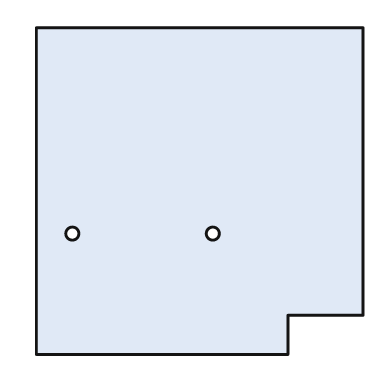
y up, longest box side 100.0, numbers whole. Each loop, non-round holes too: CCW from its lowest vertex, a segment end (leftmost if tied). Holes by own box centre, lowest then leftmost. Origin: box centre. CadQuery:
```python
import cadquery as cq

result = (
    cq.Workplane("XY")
    .moveTo(-50.0, -50.0)
    .lineTo(27.0, -50.0)
    .lineTo(27.0, -38.0)
    .lineTo(50.0, -38.0)
    .lineTo(50.0, 50.0)
    .lineTo(-50.0, 50.0)
    .close()
    .moveTo(-39.0, -13.0)
    .circle(2.0)
    .moveTo(4.0, -13.0)
    .circle(2.0)
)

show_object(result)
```